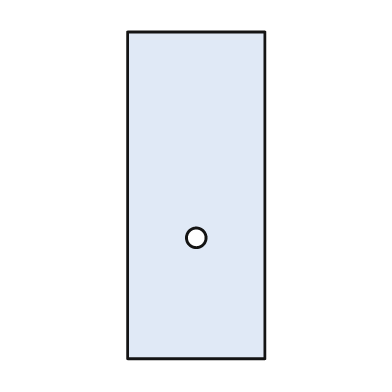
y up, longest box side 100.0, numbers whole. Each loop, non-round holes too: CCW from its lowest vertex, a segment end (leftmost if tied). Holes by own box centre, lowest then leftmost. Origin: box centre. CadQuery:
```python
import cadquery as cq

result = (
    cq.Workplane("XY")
    .moveTo(-21.0, -50.0)
    .lineTo(21.0, -50.0)
    .lineTo(21.0, 50.0)
    .lineTo(-21.0, 50.0)
    .close()
    .moveTo(0.0, -13.0)
    .circle(3.0)
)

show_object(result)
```